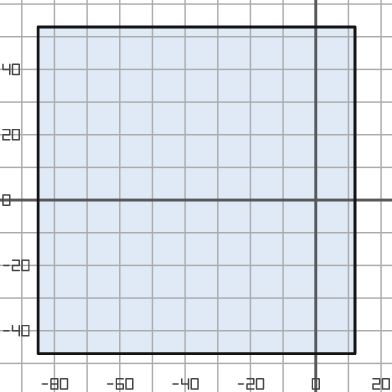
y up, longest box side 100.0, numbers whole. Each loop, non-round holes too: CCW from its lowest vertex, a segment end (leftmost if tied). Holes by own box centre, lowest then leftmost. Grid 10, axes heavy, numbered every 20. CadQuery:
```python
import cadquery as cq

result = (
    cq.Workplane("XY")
    .moveTo(-85.0, -47.0)
    .lineTo(12.0, -47.0)
    .lineTo(12.0, 53.0)
    .lineTo(-85.0, 53.0)
    .close()
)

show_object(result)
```